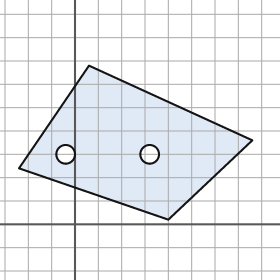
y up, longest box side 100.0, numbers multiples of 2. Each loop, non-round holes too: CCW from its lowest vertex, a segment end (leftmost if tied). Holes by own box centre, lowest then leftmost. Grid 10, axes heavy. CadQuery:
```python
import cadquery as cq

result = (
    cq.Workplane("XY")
    .moveTo(40.0, 2.0)
    .lineTo(76.0, 36.0)
    .lineTo(6.0, 68.0)
    .lineTo(-24.0, 24.0)
    .close()
    .moveTo(-4.0, 30.0)
    .circle(4.0)
    .moveTo(32.0, 30.0)
    .circle(4.0)
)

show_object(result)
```